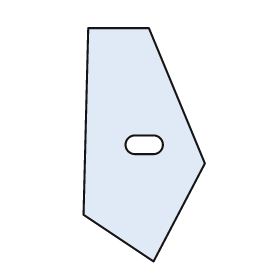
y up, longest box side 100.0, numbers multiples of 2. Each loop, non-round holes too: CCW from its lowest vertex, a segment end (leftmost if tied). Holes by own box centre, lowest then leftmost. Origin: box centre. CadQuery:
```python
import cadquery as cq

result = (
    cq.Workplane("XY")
    .moveTo(4.0, -50.0)
    .lineTo(26.0, -8.0)
    .lineTo(2.0, 50.0)
    .lineTo(-24.0, 50.0)
    .lineTo(-26.0, -30.0)
    .close()
    .moveTo(-4.0, -4.0)
    .lineTo(4.0, -4.0)
    .threePointArc((8.0, 0.0), (4.0, 4.0))
    .lineTo(-4.0, 4.0)
    .threePointArc((-8.0, 0.0), (-4.0, -4.0))
    .close()
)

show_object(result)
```